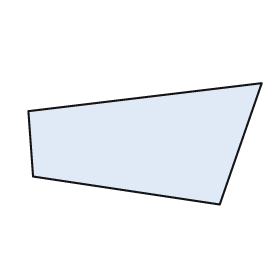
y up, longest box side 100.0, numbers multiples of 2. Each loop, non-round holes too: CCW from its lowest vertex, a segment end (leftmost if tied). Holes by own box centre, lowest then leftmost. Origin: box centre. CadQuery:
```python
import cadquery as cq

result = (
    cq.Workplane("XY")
    .moveTo(32.0, -26.0)
    .lineTo(50.0, 26.0)
    .lineTo(-50.0, 14.0)
    .lineTo(-48.0, -14.0)
    .close()
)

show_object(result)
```